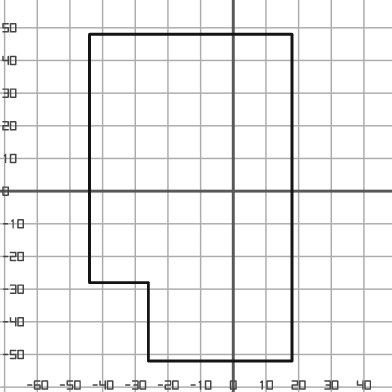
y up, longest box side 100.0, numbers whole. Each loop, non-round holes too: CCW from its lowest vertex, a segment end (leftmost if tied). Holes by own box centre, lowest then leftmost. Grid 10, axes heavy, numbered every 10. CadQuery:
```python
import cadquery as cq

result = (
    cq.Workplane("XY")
    .moveTo(-26.0, -52.0)
    .lineTo(18.0, -52.0)
    .lineTo(18.0, 48.0)
    .lineTo(-44.0, 48.0)
    .lineTo(-44.0, -28.0)
    .lineTo(-26.0, -28.0)
    .close()
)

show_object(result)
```